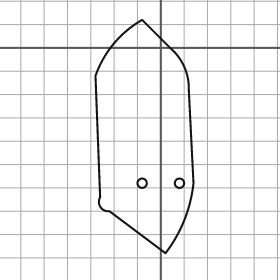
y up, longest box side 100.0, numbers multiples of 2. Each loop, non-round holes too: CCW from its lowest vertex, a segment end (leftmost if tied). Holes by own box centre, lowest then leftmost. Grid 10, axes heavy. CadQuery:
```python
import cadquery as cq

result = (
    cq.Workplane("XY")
    .moveTo(2.0, -88.0)
    .threePointArc((10.0, -74.0), (14.0, -58.0))
    .lineTo(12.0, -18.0)
    .threePointArc((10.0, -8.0), (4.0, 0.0))
    .lineTo(-8.0, 12.0)
    .threePointArc((-20.0, 2.0), (-28.0, -12.0))
    .lineTo(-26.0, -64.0)
    .threePointArc((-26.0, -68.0), (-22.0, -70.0))
    .close()
    .moveTo(-8.0, -58.0)
    .circle(2.0)
    .moveTo(8.0, -58.0)
    .circle(2.0)
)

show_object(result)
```